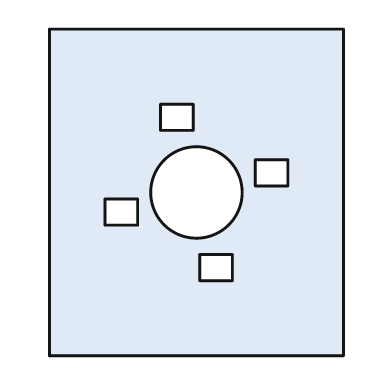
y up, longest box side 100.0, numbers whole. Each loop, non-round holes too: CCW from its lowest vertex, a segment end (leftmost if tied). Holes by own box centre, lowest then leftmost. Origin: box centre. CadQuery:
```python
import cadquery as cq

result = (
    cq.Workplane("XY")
    .moveTo(-45.0, -50.0)
    .lineTo(45.0, -50.0)
    .lineTo(45.0, 50.0)
    .lineTo(-45.0, 50.0)
    .close()
    .moveTo(1.0, -27.0)
    .lineTo(11.0, -27.0)
    .lineTo(11.0, -19.0)
    .lineTo(1.0, -19.0)
    .close()
    .moveTo(-28.0, -10.0)
    .lineTo(-18.0, -10.0)
    .lineTo(-18.0, -2.0)
    .lineTo(-28.0, -2.0)
    .close()
    .moveTo(0.0, 0.0)
    .circle(14.0)
    .moveTo(18.0, 2.0)
    .lineTo(28.0, 2.0)
    .lineTo(28.0, 10.0)
    .lineTo(18.0, 10.0)
    .close()
    .moveTo(-11.0, 19.0)
    .lineTo(-1.0, 19.0)
    .lineTo(-1.0, 27.0)
    .lineTo(-11.0, 27.0)
    .close()
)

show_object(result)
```